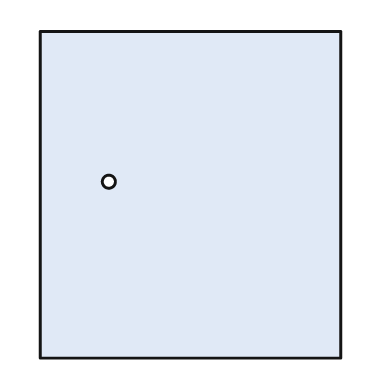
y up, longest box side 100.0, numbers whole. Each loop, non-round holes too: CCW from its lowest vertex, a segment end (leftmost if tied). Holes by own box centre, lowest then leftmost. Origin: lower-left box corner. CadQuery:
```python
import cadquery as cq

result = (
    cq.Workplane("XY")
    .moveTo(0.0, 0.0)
    .lineTo(92.0, 0.0)
    .lineTo(92.0, 100.0)
    .lineTo(0.0, 100.0)
    .close()
    .moveTo(21.0, 54.0)
    .circle(2.0)
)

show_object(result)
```